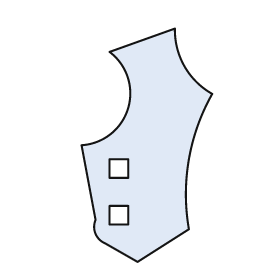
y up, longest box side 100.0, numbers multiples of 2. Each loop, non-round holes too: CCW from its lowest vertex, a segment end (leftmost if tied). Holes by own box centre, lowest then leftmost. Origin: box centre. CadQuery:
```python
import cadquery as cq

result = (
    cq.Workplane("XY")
    .moveTo(-4.0, -50.0)
    .lineTo(18.0, -36.0)
    .threePointArc((18.0, -6.0), (28.0, 22.0))
    .threePointArc((16.0, 34.0), (12.0, 50.0))
    .lineTo(-16.0, 40.0)
    .threePointArc((-8.0, 16.0), (-28.0, 0.0))
    .lineTo(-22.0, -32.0)
    .threePointArc((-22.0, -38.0), (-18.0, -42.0))
    .close()
    .moveTo(-16.0, -34.0)
    .lineTo(-8.0, -34.0)
    .lineTo(-8.0, -26.0)
    .lineTo(-16.0, -26.0)
    .close()
    .moveTo(-16.0, -14.0)
    .lineTo(-8.0, -14.0)
    .lineTo(-8.0, -6.0)
    .lineTo(-16.0, -6.0)
    .close()
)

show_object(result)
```